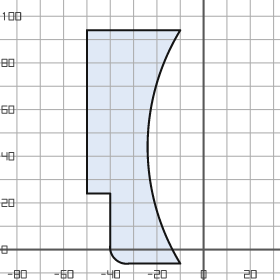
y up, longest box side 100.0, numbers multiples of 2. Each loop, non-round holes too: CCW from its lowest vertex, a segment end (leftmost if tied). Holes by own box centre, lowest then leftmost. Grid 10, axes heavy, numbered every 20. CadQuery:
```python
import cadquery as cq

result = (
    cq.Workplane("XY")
    .moveTo(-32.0, -6.0)
    .lineTo(-10.0, -6.0)
    .threePointArc((-24.0, 44.0), (-10.0, 94.0))
    .lineTo(-50.0, 94.0)
    .lineTo(-50.0, 24.0)
    .lineTo(-40.0, 24.0)
    .lineTo(-40.0, 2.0)
    .threePointArc((-38.0, -4.0), (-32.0, -6.0))
    .close()
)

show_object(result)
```